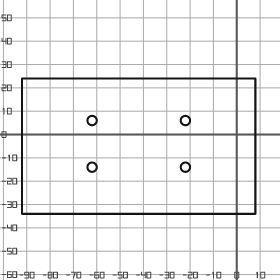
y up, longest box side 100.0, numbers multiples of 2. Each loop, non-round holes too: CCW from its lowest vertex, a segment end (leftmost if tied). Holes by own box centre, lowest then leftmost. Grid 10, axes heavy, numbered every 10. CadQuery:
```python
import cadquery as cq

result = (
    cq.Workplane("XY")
    .moveTo(-92.0, -34.0)
    .lineTo(8.0, -34.0)
    .lineTo(8.0, 24.0)
    .lineTo(-92.0, 24.0)
    .close()
    .moveTo(-62.0, -14.0)
    .circle(2.0)
    .moveTo(-22.0, -14.0)
    .circle(2.0)
    .moveTo(-62.0, 6.0)
    .circle(2.0)
    .moveTo(-22.0, 6.0)
    .circle(2.0)
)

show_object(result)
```